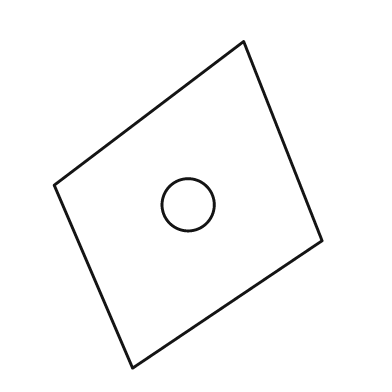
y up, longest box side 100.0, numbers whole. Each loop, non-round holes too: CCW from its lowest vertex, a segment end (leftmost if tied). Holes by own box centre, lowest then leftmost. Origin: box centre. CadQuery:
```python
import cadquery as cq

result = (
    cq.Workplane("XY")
    .moveTo(-17.0, -50.0)
    .lineTo(41.0, -11.0)
    .lineTo(17.0, 50.0)
    .lineTo(-41.0, 6.0)
    .close()
    .moveTo(0.0, 0.0)
    .circle(8.0)
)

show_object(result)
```